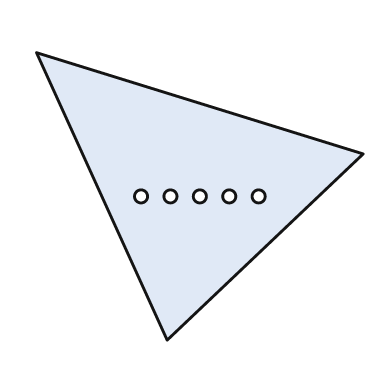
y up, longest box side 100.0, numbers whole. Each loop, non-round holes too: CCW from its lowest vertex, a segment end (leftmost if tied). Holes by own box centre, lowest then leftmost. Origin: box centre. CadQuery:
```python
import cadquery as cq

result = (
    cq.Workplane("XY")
    .moveTo(-10.0, -44.0)
    .lineTo(50.0, 13.0)
    .lineTo(-50.0, 44.0)
    .close()
    .moveTo(-18.0, 0.0)
    .circle(2.0)
    .moveTo(-9.0, 0.0)
    .circle(2.0)
    .moveTo(0.0, 0.0)
    .circle(2.0)
    .moveTo(9.0, 0.0)
    .circle(2.0)
    .moveTo(18.0, 0.0)
    .circle(2.0)
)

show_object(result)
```